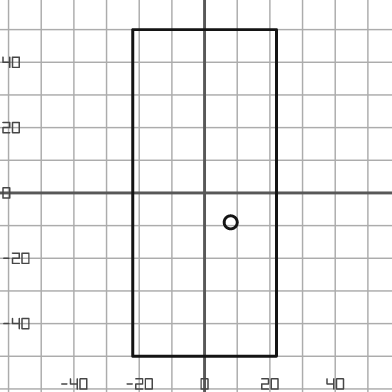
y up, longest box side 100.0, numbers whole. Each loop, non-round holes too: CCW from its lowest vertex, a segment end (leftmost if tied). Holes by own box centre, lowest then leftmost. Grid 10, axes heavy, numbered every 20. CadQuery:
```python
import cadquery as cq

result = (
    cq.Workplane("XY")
    .moveTo(-22.0, -50.0)
    .lineTo(22.0, -50.0)
    .lineTo(22.0, 50.0)
    .lineTo(-22.0, 50.0)
    .close()
    .moveTo(8.0, -9.0)
    .circle(2.0)
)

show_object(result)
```